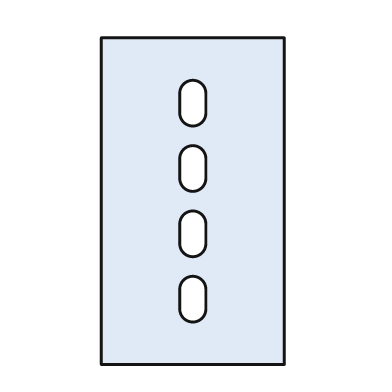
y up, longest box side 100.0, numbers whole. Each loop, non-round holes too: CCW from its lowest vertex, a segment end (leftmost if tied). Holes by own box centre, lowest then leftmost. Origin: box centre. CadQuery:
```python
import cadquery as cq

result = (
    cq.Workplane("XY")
    .moveTo(-28.0, -50.0)
    .lineTo(28.0, -50.0)
    .lineTo(28.0, 50.0)
    .lineTo(-28.0, 50.0)
    .close()
    .moveTo(-4.0, -33.0)
    .threePointArc((0.0, -37.0), (4.0, -33.0))
    .lineTo(4.0, -27.0)
    .threePointArc((0.0, -23.0), (-4.0, -27.0))
    .close()
    .moveTo(-4.0, -13.0)
    .threePointArc((0.0, -17.0), (4.0, -13.0))
    .lineTo(4.0, -7.0)
    .threePointArc((0.0, -3.0), (-4.0, -7.0))
    .close()
    .moveTo(-4.0, 7.0)
    .threePointArc((0.0, 3.0), (4.0, 7.0))
    .lineTo(4.0, 13.0)
    .threePointArc((0.0, 17.0), (-4.0, 13.0))
    .close()
    .moveTo(-4.0, 27.0)
    .threePointArc((0.0, 23.0), (4.0, 27.0))
    .lineTo(4.0, 33.0)
    .threePointArc((0.0, 37.0), (-4.0, 33.0))
    .close()
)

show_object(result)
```